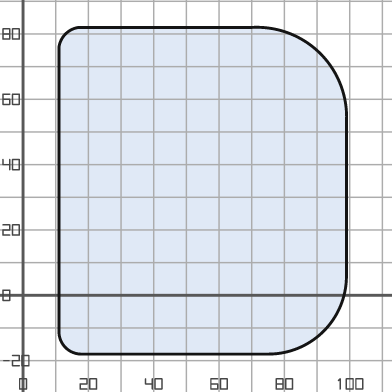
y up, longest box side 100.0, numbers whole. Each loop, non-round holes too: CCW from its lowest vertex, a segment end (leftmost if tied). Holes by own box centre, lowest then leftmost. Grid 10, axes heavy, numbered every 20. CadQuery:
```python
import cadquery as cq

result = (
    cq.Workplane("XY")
    .moveTo(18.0, -18.0)
    .lineTo(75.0, -18.0)
    .threePointArc((92.0, -11.0), (99.0, 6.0))
    .lineTo(99.0, 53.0)
    .threePointArc((91.0, 74.0), (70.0, 82.0))
    .lineTo(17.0, 82.0)
    .threePointArc((13.0, 80.0), (11.0, 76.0))
    .lineTo(11.0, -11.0)
    .threePointArc((13.0, -16.0), (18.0, -18.0))
    .close()
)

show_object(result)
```